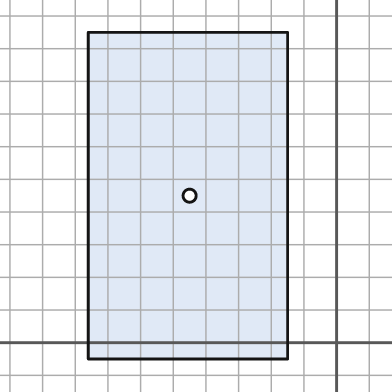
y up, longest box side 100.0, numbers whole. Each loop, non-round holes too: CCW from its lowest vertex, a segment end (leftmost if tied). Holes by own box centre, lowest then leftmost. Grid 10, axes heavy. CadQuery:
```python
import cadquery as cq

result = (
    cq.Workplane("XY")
    .moveTo(-76.0, -5.0)
    .lineTo(-15.0, -5.0)
    .lineTo(-15.0, 95.0)
    .lineTo(-76.0, 95.0)
    .close()
    .moveTo(-45.0, 45.0)
    .circle(2.0)
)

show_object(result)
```